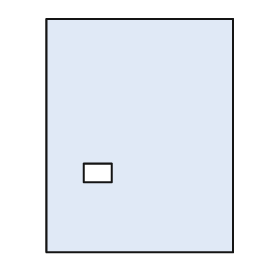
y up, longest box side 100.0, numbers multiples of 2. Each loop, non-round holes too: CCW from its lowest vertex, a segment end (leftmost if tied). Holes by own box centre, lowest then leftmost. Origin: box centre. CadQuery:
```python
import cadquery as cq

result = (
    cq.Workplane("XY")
    .moveTo(-40.0, -50.0)
    .lineTo(40.0, -50.0)
    .lineTo(40.0, 50.0)
    .lineTo(-40.0, 50.0)
    .close()
    .moveTo(-24.0, -20.0)
    .lineTo(-12.0, -20.0)
    .lineTo(-12.0, -12.0)
    .lineTo(-24.0, -12.0)
    .close()
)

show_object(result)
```